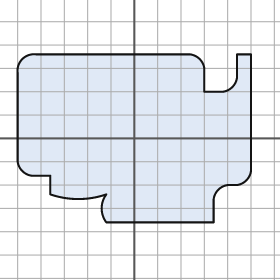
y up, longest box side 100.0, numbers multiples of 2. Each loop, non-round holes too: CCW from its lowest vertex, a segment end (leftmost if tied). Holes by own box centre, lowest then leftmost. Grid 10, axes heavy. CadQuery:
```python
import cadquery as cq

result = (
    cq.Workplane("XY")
    .moveTo(-12.0, -36.0)
    .lineTo(34.0, -36.0)
    .lineTo(34.0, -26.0)
    .threePointArc((36.0, -22.0), (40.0, -20.0))
    .lineTo(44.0, -20.0)
    .threePointArc((48.0, -18.0), (50.0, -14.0))
    .lineTo(50.0, 36.0)
    .lineTo(44.0, 36.0)
    .lineTo(44.0, 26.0)
    .threePointArc((42.0, 22.0), (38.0, 20.0))
    .lineTo(30.0, 20.0)
    .lineTo(30.0, 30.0)
    .threePointArc((28.0, 34.0), (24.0, 36.0))
    .lineTo(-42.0, 36.0)
    .threePointArc((-48.0, 34.0), (-50.0, 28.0))
    .lineTo(-50.0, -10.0)
    .threePointArc((-48.0, -14.0), (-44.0, -16.0))
    .lineTo(-36.0, -16.0)
    .lineTo(-36.0, -24.0)
    .threePointArc((-24.0, -26.0), (-12.0, -24.0))
    .threePointArc((-14.0, -30.0), (-12.0, -36.0))
    .close()
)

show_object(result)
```